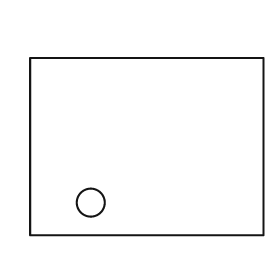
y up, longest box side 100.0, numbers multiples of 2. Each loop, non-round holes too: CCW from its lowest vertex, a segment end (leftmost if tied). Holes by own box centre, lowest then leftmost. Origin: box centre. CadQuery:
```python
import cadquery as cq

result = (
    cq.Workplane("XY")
    .moveTo(-50.0, -38.0)
    .lineTo(50.0, -38.0)
    .lineTo(50.0, 38.0)
    .lineTo(-50.0, 38.0)
    .close()
    .moveTo(-24.0, -24.0)
    .circle(6.0)
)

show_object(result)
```